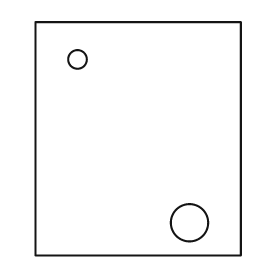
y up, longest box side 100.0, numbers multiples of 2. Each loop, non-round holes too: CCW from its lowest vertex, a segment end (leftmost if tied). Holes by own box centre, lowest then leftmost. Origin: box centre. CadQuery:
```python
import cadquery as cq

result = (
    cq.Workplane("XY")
    .moveTo(-44.0, -50.0)
    .lineTo(44.0, -50.0)
    .lineTo(44.0, 50.0)
    .lineTo(-44.0, 50.0)
    .close()
    .moveTo(22.0, -36.0)
    .circle(8.0)
    .moveTo(-26.0, 34.0)
    .circle(4.0)
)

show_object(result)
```